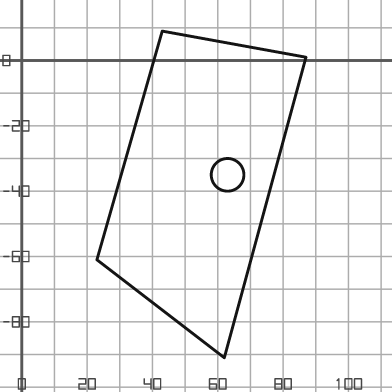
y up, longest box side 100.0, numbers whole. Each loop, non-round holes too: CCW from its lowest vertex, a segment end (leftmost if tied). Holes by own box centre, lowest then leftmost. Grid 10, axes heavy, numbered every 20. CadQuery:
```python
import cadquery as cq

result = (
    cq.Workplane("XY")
    .moveTo(62.0, -91.0)
    .lineTo(87.0, 1.0)
    .lineTo(43.0, 9.0)
    .lineTo(23.0, -61.0)
    .close()
    .moveTo(63.0, -35.0)
    .circle(5.0)
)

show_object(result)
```